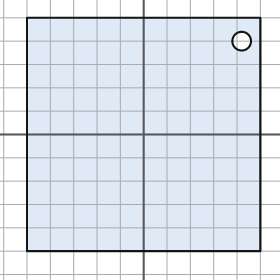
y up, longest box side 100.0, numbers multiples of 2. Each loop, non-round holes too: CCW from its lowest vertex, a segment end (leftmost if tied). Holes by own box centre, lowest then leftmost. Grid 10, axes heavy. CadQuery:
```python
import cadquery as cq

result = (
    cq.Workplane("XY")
    .moveTo(-50.0, -50.0)
    .lineTo(50.0, -50.0)
    .lineTo(50.0, 50.0)
    .lineTo(-50.0, 50.0)
    .close()
    .moveTo(42.0, 40.0)
    .circle(4.0)
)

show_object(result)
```